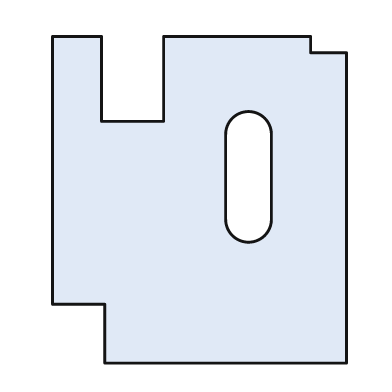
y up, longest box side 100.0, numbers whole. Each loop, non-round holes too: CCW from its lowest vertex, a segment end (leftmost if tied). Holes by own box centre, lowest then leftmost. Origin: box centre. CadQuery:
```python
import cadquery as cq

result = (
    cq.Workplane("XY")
    .moveTo(-29.0, -50.0)
    .lineTo(45.0, -50.0)
    .lineTo(45.0, 45.0)
    .lineTo(34.0, 45.0)
    .lineTo(34.0, 50.0)
    .lineTo(-11.0, 50.0)
    .lineTo(-11.0, 24.0)
    .lineTo(-30.0, 24.0)
    .lineTo(-30.0, 50.0)
    .lineTo(-45.0, 50.0)
    .lineTo(-45.0, -32.0)
    .lineTo(-29.0, -32.0)
    .close()
    .moveTo(8.0, -6.0)
    .threePointArc((15.0, -13.0), (22.0, -6.0))
    .lineTo(22.0, 20.0)
    .threePointArc((15.0, 27.0), (8.0, 20.0))
    .close()
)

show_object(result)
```